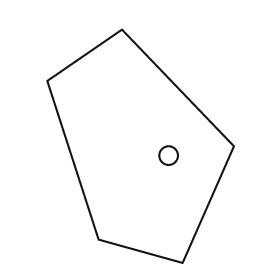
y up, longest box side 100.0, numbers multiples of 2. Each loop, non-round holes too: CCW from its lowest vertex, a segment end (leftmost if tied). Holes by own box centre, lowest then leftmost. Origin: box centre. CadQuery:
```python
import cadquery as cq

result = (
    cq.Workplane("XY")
    .moveTo(18.0, -50.0)
    .lineTo(40.0, 0.0)
    .lineTo(-8.0, 50.0)
    .lineTo(-40.0, 28.0)
    .lineTo(-18.0, -40.0)
    .close()
    .moveTo(12.0, -4.0)
    .circle(4.0)
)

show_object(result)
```